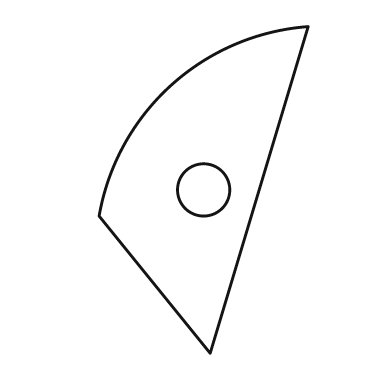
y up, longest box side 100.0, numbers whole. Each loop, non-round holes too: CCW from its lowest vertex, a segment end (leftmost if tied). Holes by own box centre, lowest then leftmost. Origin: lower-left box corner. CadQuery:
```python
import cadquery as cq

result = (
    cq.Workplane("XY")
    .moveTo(34.0, 0.0)
    .lineTo(64.0, 100.0)
    .threePointArc((22.0, 82.0), (0.0, 42.0))
    .close()
    .moveTo(32.0, 50.0)
    .circle(8.0)
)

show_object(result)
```